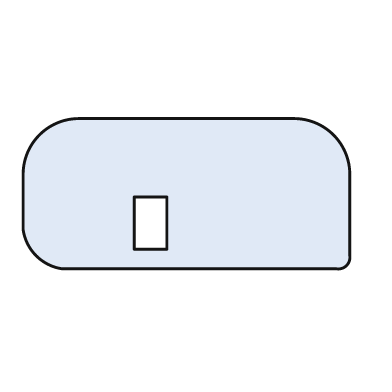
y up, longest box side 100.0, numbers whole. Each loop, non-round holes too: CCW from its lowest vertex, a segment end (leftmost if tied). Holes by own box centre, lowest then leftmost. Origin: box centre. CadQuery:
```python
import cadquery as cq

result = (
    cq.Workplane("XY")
    .moveTo(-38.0, -23.0)
    .lineTo(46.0, -23.0)
    .threePointArc((49.0, -22.0), (50.0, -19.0))
    .lineTo(50.0, 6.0)
    .threePointArc((45.0, 18.0), (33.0, 23.0))
    .lineTo(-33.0, 23.0)
    .threePointArc((-45.0, 18.0), (-50.0, 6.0))
    .lineTo(-50.0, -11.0)
    .threePointArc((-46.0, -19.0), (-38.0, -23.0))
    .close()
    .moveTo(-16.0, -17.0)
    .lineTo(-6.0, -17.0)
    .lineTo(-6.0, -1.0)
    .lineTo(-16.0, -1.0)
    .close()
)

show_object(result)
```